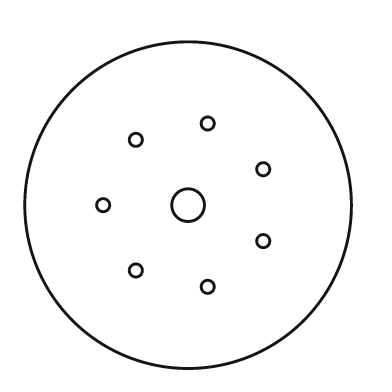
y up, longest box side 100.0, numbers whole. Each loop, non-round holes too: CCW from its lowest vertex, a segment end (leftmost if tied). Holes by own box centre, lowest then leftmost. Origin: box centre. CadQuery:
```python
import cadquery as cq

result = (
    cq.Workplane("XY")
    .moveTo(0.0, 0.0)
    .circle(50.0)
    .moveTo(6.0, -25.0)
    .circle(2.0)
    .moveTo(-16.0, -20.0)
    .circle(2.0)
    .moveTo(23.0, -11.0)
    .circle(2.0)
    .moveTo(-26.0, 0.0)
    .circle(2.0)
    .moveTo(0.0, 0.0)
    .circle(5.0)
    .moveTo(23.0, 11.0)
    .circle(2.0)
    .moveTo(-16.0, 20.0)
    .circle(2.0)
    .moveTo(6.0, 25.0)
    .circle(2.0)
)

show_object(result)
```